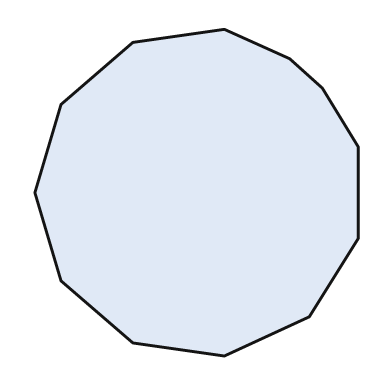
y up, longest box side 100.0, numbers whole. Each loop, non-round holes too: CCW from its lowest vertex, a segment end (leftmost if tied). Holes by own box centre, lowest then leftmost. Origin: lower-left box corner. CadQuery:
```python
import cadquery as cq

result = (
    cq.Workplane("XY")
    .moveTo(58.0, 0.0)
    .lineTo(84.0, 12.0)
    .lineTo(99.0, 36.0)
    .lineTo(99.0, 64.0)
    .lineTo(88.0, 82.0)
    .lineTo(78.0, 91.0)
    .lineTo(58.0, 100.0)
    .lineTo(30.0, 96.0)
    .lineTo(8.0, 77.0)
    .lineTo(0.0, 50.0)
    .lineTo(8.0, 23.0)
    .lineTo(30.0, 4.0)
    .close()
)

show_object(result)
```